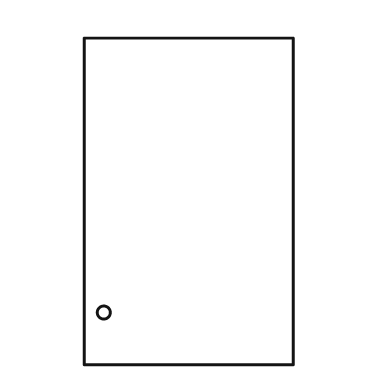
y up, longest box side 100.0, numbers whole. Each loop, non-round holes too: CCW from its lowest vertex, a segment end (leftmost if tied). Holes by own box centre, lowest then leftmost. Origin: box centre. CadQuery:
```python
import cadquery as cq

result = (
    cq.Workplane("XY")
    .moveTo(-32.0, -50.0)
    .lineTo(32.0, -50.0)
    .lineTo(32.0, 50.0)
    .lineTo(-32.0, 50.0)
    .close()
    .moveTo(-26.0, -34.0)
    .circle(2.0)
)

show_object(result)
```